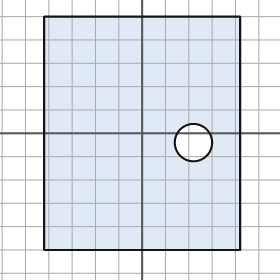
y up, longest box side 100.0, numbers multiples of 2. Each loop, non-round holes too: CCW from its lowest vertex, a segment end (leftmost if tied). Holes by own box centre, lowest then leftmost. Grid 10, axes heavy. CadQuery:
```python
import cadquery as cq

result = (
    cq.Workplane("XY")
    .moveTo(-42.0, -50.0)
    .lineTo(42.0, -50.0)
    .lineTo(42.0, 50.0)
    .lineTo(-42.0, 50.0)
    .close()
    .moveTo(22.0, -4.0)
    .circle(8.0)
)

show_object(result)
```